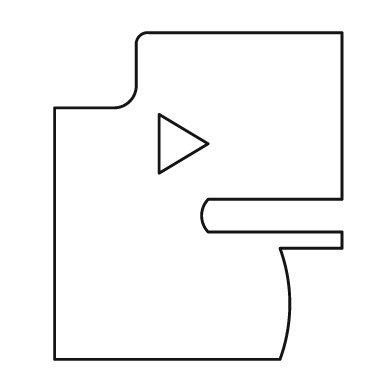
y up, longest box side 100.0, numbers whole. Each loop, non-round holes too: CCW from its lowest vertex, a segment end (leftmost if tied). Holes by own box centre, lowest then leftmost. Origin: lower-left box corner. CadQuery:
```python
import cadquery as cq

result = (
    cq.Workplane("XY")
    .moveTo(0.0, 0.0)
    .lineTo(69.0, 0.0)
    .threePointArc((72.0, 17.0), (69.0, 34.0))
    .lineTo(88.0, 34.0)
    .lineTo(88.0, 39.0)
    .lineTo(47.0, 39.0)
    .threePointArc((45.0, 44.0), (47.0, 49.0))
    .lineTo(88.0, 49.0)
    .lineTo(88.0, 100.0)
    .lineTo(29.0, 100.0)
    .threePointArc((26.0, 99.0), (25.0, 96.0))
    .lineTo(25.0, 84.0)
    .threePointArc((23.0, 79.0), (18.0, 77.0))
    .lineTo(0.0, 77.0)
    .close()
    .moveTo(32.0, 57.0)
    .lineTo(47.0, 66.0)
    .lineTo(32.0, 75.0)
    .close()
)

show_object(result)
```